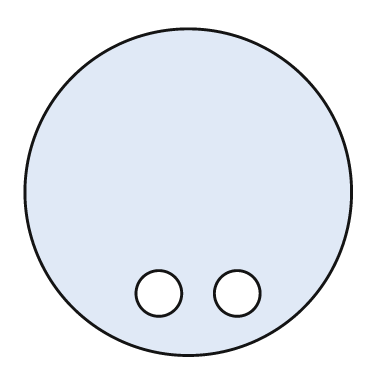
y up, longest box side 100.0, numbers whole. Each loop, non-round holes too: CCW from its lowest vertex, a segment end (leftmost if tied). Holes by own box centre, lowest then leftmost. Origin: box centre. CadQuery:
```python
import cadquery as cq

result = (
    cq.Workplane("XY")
    .moveTo(0.0, 0.0)
    .circle(50.0)
    .moveTo(-9.0, -31.0)
    .circle(7.0)
    .moveTo(15.0, -31.0)
    .circle(7.0)
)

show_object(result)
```